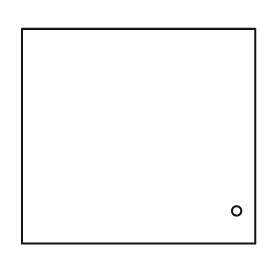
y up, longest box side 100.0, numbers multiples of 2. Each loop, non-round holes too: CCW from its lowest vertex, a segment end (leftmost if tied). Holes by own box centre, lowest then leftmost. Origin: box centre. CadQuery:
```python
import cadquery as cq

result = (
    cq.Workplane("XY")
    .moveTo(-50.0, -46.0)
    .lineTo(50.0, -46.0)
    .lineTo(50.0, 46.0)
    .lineTo(-50.0, 46.0)
    .close()
    .moveTo(42.0, -32.0)
    .circle(2.0)
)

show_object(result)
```